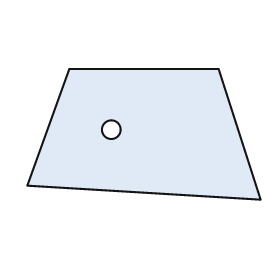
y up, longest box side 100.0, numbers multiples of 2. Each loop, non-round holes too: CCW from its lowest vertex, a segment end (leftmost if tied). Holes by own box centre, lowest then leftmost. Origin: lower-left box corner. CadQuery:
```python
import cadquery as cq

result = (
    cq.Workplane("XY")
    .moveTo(100.0, 0.0)
    .lineTo(82.0, 56.0)
    .lineTo(18.0, 56.0)
    .lineTo(0.0, 6.0)
    .close()
    .moveTo(36.0, 30.0)
    .circle(4.0)
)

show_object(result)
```